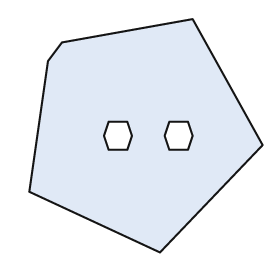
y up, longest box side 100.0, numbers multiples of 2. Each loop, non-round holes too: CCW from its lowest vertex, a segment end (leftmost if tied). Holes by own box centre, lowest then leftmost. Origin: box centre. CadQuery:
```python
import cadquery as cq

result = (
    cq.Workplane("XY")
    .moveTo(6.0, -50.0)
    .lineTo(50.0, -4.0)
    .lineTo(20.0, 50.0)
    .lineTo(-36.0, 40.0)
    .lineTo(-42.0, 32.0)
    .lineTo(-50.0, -24.0)
    .close()
    .moveTo(-16.0, -6.0)
    .lineTo(-8.0, -6.0)
    .lineTo(-6.0, 0.0)
    .lineTo(-8.0, 6.0)
    .lineTo(-16.0, 6.0)
    .lineTo(-18.0, 0.0)
    .close()
    .moveTo(10.0, -6.0)
    .lineTo(18.0, -6.0)
    .lineTo(20.0, 0.0)
    .lineTo(18.0, 6.0)
    .lineTo(10.0, 6.0)
    .lineTo(8.0, 0.0)
    .close()
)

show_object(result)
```